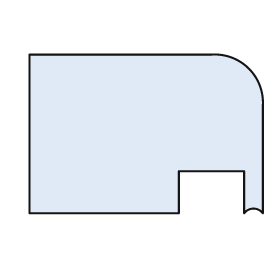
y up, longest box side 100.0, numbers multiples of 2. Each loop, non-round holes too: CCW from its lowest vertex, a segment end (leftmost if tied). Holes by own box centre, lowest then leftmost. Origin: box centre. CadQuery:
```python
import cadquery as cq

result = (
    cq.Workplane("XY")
    .moveTo(-50.0, -34.0)
    .lineTo(14.0, -34.0)
    .lineTo(14.0, -16.0)
    .lineTo(42.0, -16.0)
    .lineTo(42.0, -34.0)
    .threePointArc((46.0, -32.0), (50.0, -34.0))
    .lineTo(50.0, 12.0)
    .threePointArc((44.0, 28.0), (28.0, 34.0))
    .lineTo(-50.0, 34.0)
    .close()
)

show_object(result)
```